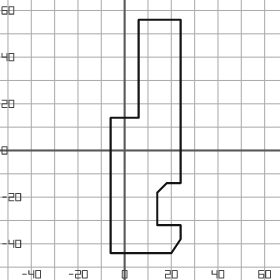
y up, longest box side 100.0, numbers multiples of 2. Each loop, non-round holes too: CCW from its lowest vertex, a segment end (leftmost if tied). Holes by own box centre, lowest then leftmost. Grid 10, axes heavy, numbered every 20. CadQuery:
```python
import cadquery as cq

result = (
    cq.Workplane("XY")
    .moveTo(-6.0, -44.0)
    .lineTo(20.0, -44.0)
    .lineTo(24.0, -38.0)
    .lineTo(24.0, -32.0)
    .lineTo(14.0, -32.0)
    .lineTo(14.0, -18.0)
    .lineTo(18.0, -14.0)
    .lineTo(24.0, -14.0)
    .lineTo(24.0, 56.0)
    .lineTo(6.0, 56.0)
    .lineTo(6.0, 14.0)
    .lineTo(-6.0, 14.0)
    .close()
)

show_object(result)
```